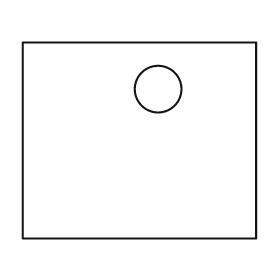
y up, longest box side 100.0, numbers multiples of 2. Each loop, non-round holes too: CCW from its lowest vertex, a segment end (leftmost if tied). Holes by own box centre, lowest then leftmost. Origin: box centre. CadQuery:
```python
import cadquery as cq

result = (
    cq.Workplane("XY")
    .moveTo(-50.0, -42.0)
    .lineTo(50.0, -42.0)
    .lineTo(50.0, 42.0)
    .lineTo(-50.0, 42.0)
    .close()
    .moveTo(8.0, 22.0)
    .circle(10.0)
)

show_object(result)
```